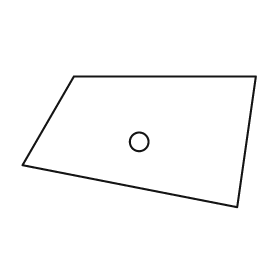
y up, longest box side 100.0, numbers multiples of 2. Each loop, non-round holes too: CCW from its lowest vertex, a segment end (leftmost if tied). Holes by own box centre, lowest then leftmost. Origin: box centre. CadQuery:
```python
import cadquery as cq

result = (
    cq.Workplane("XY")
    .moveTo(42.0, -28.0)
    .lineTo(50.0, 28.0)
    .lineTo(-28.0, 28.0)
    .lineTo(-50.0, -10.0)
    .close()
    .moveTo(0.0, 0.0)
    .circle(4.0)
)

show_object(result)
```